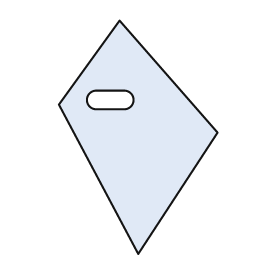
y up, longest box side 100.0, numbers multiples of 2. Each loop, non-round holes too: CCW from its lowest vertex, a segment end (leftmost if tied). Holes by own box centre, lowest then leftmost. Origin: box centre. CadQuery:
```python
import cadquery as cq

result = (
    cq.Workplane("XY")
    .moveTo(0.0, -50.0)
    .lineTo(34.0, 2.0)
    .lineTo(-8.0, 50.0)
    .lineTo(-34.0, 14.0)
    .close()
    .moveTo(-18.0, 12.0)
    .lineTo(-6.0, 12.0)
    .threePointArc((-2.0, 16.0), (-6.0, 20.0))
    .lineTo(-18.0, 20.0)
    .threePointArc((-22.0, 16.0), (-18.0, 12.0))
    .close()
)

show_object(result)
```